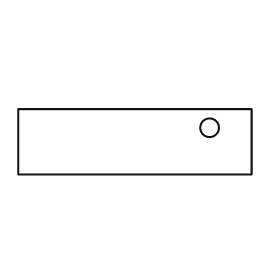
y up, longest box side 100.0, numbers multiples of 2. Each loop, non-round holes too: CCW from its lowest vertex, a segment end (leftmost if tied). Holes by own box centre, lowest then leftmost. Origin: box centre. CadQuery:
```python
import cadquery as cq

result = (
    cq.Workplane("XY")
    .moveTo(-50.0, -14.0)
    .lineTo(50.0, -14.0)
    .lineTo(50.0, 14.0)
    .lineTo(-50.0, 14.0)
    .close()
    .moveTo(32.0, 6.0)
    .circle(4.0)
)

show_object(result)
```